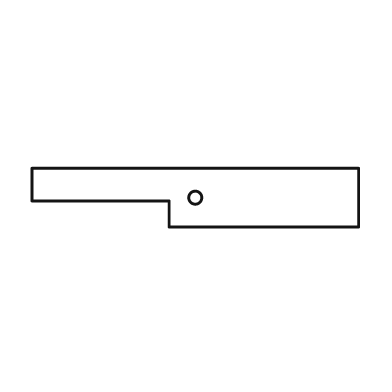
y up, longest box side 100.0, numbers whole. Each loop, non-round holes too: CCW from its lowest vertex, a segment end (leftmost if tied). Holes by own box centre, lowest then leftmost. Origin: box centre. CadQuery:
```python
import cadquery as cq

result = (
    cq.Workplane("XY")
    .moveTo(-8.0, -9.0)
    .lineTo(50.0, -9.0)
    .lineTo(50.0, 9.0)
    .lineTo(-50.0, 9.0)
    .lineTo(-50.0, -1.0)
    .lineTo(-8.0, -1.0)
    .close()
    .moveTo(0.0, 0.0)
    .circle(2.0)
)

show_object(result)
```